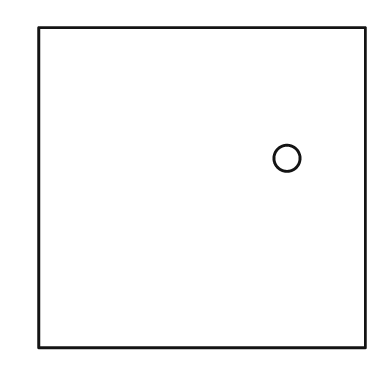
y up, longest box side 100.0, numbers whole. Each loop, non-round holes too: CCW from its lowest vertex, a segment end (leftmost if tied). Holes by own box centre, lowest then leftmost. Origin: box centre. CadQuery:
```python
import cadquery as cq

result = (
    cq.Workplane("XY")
    .moveTo(-50.0, -49.0)
    .lineTo(50.0, -49.0)
    .lineTo(50.0, 49.0)
    .lineTo(-50.0, 49.0)
    .close()
    .moveTo(26.0, 9.0)
    .circle(4.0)
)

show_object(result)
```